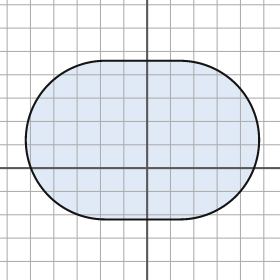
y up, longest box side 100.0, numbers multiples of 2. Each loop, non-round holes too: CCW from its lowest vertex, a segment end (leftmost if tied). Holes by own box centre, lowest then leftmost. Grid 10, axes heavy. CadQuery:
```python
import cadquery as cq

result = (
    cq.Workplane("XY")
    .moveTo(-18.0, -22.0)
    .lineTo(14.0, -22.0)
    .threePointArc((48.0, 12.0), (14.0, 46.0))
    .lineTo(-18.0, 46.0)
    .threePointArc((-52.0, 12.0), (-18.0, -22.0))
    .close()
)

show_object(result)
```